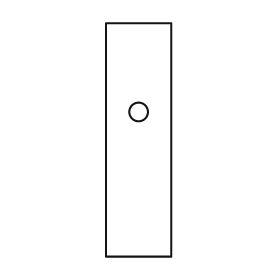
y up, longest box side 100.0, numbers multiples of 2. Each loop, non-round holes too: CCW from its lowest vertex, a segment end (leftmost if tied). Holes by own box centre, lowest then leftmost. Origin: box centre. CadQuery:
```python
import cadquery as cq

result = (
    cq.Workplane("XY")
    .moveTo(-14.0, -50.0)
    .lineTo(14.0, -50.0)
    .lineTo(14.0, 50.0)
    .lineTo(-14.0, 50.0)
    .close()
    .moveTo(0.0, 12.0)
    .circle(4.0)
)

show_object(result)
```